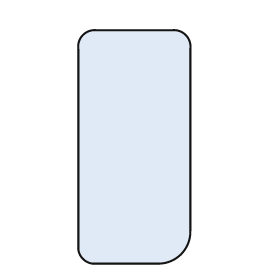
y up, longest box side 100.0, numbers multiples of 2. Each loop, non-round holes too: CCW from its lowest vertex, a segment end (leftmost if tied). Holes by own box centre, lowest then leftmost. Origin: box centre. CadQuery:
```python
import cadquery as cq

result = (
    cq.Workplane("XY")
    .moveTo(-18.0, -50.0)
    .lineTo(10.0, -50.0)
    .threePointArc((20.0, -46.0), (24.0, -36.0))
    .lineTo(24.0, 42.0)
    .threePointArc((22.0, 48.0), (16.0, 50.0))
    .lineTo(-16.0, 50.0)
    .threePointArc((-22.0, 48.0), (-24.0, 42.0))
    .lineTo(-24.0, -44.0)
    .threePointArc((-22.0, -48.0), (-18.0, -50.0))
    .close()
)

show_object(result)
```